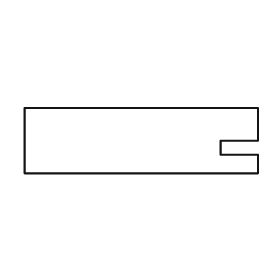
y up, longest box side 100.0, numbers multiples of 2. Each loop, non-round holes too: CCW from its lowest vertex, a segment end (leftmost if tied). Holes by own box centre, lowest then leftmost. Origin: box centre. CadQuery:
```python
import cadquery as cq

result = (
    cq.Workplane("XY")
    .moveTo(-50.0, -14.0)
    .lineTo(50.0, -14.0)
    .lineTo(50.0, -6.0)
    .lineTo(34.0, -6.0)
    .lineTo(34.0, 0.0)
    .lineTo(50.0, 0.0)
    .lineTo(50.0, 14.0)
    .lineTo(-50.0, 14.0)
    .close()
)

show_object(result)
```